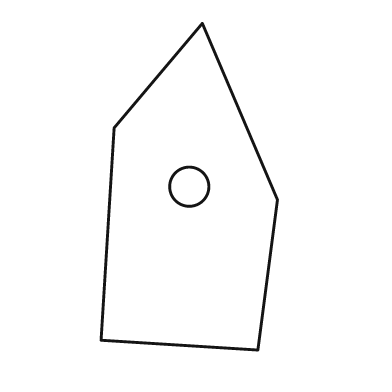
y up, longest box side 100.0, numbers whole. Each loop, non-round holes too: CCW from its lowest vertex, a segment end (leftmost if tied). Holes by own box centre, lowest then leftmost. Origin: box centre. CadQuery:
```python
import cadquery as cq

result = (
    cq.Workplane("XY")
    .moveTo(21.0, -50.0)
    .lineTo(27.0, -4.0)
    .lineTo(4.0, 50.0)
    .lineTo(-23.0, 18.0)
    .lineTo(-27.0, -47.0)
    .close()
    .moveTo(0.0, 0.0)
    .circle(6.0)
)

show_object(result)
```